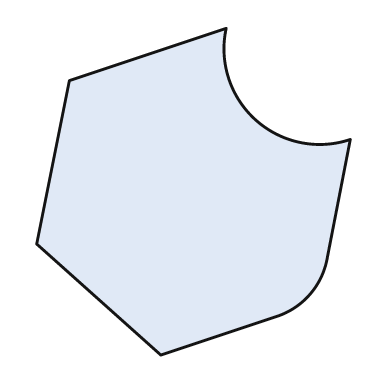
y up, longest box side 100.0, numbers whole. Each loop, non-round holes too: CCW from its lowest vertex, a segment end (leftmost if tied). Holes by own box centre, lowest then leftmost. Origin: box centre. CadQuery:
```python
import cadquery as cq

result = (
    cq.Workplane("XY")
    .moveTo(-10.0, -50.0)
    .lineTo(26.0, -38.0)
    .threePointArc((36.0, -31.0), (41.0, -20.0))
    .lineTo(48.0, 16.0)
    .threePointArc((19.0, 22.0), (10.0, 50.0))
    .lineTo(-38.0, 34.0)
    .lineTo(-48.0, -16.0)
    .close()
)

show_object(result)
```